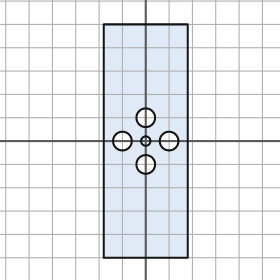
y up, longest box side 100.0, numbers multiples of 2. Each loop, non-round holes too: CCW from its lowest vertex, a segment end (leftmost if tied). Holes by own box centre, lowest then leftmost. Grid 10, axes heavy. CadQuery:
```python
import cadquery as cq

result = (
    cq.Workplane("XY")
    .moveTo(-18.0, -50.0)
    .lineTo(18.0, -50.0)
    .lineTo(18.0, 50.0)
    .lineTo(-18.0, 50.0)
    .close()
    .moveTo(0.0, -10.0)
    .circle(4.0)
    .moveTo(-10.0, 0.0)
    .circle(4.0)
    .moveTo(0.0, 0.0)
    .circle(2.0)
    .moveTo(10.0, 0.0)
    .circle(4.0)
    .moveTo(0.0, 10.0)
    .circle(4.0)
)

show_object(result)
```